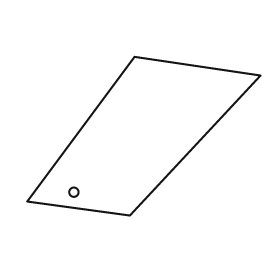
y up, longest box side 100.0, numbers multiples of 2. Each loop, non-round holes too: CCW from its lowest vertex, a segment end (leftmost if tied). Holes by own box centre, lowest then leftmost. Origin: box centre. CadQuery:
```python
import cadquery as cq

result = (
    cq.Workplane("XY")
    .moveTo(-6.0, -34.0)
    .lineTo(50.0, 26.0)
    .lineTo(-4.0, 34.0)
    .lineTo(-50.0, -28.0)
    .close()
    .moveTo(-30.0, -24.0)
    .circle(2.0)
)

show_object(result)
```